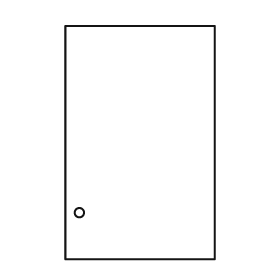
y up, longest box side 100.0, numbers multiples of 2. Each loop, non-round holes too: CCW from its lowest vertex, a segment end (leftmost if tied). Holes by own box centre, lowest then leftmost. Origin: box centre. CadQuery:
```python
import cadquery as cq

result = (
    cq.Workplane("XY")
    .moveTo(-32.0, -50.0)
    .lineTo(32.0, -50.0)
    .lineTo(32.0, 50.0)
    .lineTo(-32.0, 50.0)
    .close()
    .moveTo(-26.0, -30.0)
    .circle(2.0)
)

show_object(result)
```